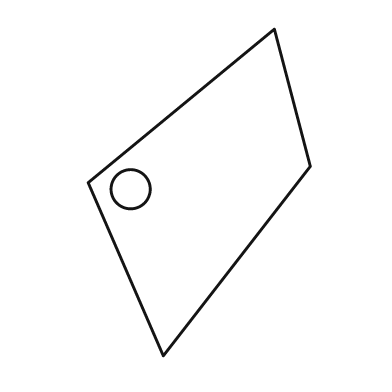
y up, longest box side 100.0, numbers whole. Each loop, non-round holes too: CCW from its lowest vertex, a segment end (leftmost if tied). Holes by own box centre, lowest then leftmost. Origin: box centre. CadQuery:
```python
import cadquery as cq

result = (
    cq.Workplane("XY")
    .moveTo(-11.0, -50.0)
    .lineTo(34.0, 8.0)
    .lineTo(23.0, 50.0)
    .lineTo(-34.0, 3.0)
    .close()
    .moveTo(-21.0, 1.0)
    .circle(6.0)
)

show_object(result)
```